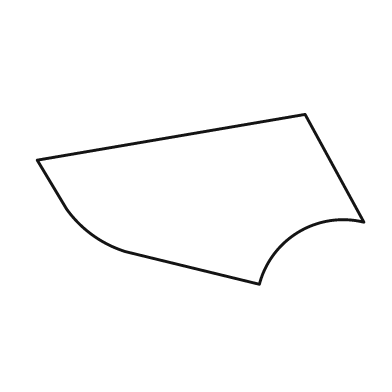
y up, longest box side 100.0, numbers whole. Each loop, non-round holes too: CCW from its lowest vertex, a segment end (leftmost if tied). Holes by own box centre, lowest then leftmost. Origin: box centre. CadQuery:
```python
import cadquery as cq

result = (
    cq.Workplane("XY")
    .moveTo(18.0, -26.0)
    .threePointArc((30.0, -10.0), (50.0, -7.0))
    .lineTo(32.0, 26.0)
    .lineTo(-50.0, 12.0)
    .lineTo(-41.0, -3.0)
    .threePointArc((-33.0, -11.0), (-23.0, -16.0))
    .close()
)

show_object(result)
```